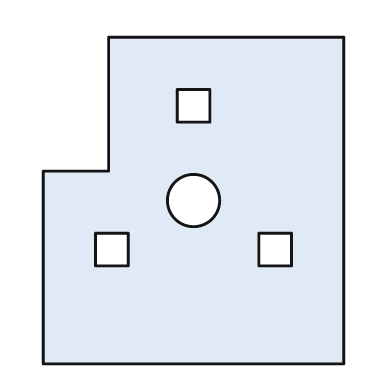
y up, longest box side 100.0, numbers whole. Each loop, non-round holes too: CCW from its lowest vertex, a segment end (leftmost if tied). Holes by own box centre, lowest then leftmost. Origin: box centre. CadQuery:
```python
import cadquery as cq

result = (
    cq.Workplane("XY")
    .moveTo(-46.0, -50.0)
    .lineTo(46.0, -50.0)
    .lineTo(46.0, 50.0)
    .lineTo(-26.0, 50.0)
    .lineTo(-26.0, 9.0)
    .lineTo(-46.0, 9.0)
    .close()
    .moveTo(-30.0, -20.0)
    .lineTo(-20.0, -20.0)
    .lineTo(-20.0, -10.0)
    .lineTo(-30.0, -10.0)
    .close()
    .moveTo(20.0, -20.0)
    .lineTo(30.0, -20.0)
    .lineTo(30.0, -10.0)
    .lineTo(20.0, -10.0)
    .close()
    .moveTo(0.0, 0.0)
    .circle(8.0)
    .moveTo(-5.0, 24.0)
    .lineTo(5.0, 24.0)
    .lineTo(5.0, 34.0)
    .lineTo(-5.0, 34.0)
    .close()
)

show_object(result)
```